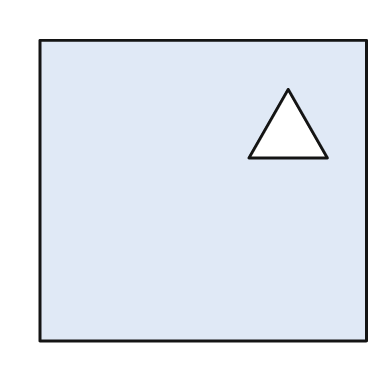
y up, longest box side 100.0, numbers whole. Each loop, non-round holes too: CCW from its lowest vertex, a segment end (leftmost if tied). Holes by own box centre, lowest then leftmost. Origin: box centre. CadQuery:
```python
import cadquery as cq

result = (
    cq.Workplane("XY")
    .moveTo(-50.0, -46.0)
    .lineTo(50.0, -46.0)
    .lineTo(50.0, 46.0)
    .lineTo(-50.0, 46.0)
    .close()
    .moveTo(14.0, 10.0)
    .lineTo(38.0, 10.0)
    .lineTo(26.0, 31.0)
    .close()
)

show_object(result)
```